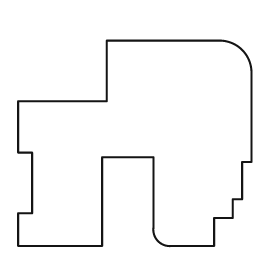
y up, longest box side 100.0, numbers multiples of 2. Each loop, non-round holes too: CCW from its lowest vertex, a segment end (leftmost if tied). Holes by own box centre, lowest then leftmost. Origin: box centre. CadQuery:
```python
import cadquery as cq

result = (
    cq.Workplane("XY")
    .moveTo(-50.0, -44.0)
    .lineTo(-14.0, -44.0)
    .lineTo(-14.0, -6.0)
    .lineTo(8.0, -6.0)
    .lineTo(8.0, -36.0)
    .threePointArc((10.0, -42.0), (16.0, -44.0))
    .lineTo(34.0, -44.0)
    .lineTo(34.0, -32.0)
    .lineTo(42.0, -32.0)
    .lineTo(42.0, -24.0)
    .lineTo(46.0, -24.0)
    .lineTo(46.0, -8.0)
    .lineTo(50.0, -8.0)
    .lineTo(50.0, 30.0)
    .threePointArc((46.0, 40.0), (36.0, 44.0))
    .lineTo(-12.0, 44.0)
    .lineTo(-12.0, 18.0)
    .lineTo(-50.0, 18.0)
    .lineTo(-50.0, -4.0)
    .lineTo(-44.0, -4.0)
    .lineTo(-44.0, -30.0)
    .lineTo(-50.0, -30.0)
    .close()
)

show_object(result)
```